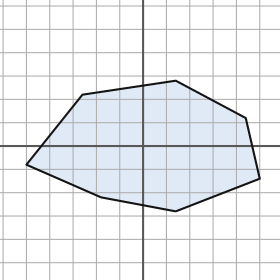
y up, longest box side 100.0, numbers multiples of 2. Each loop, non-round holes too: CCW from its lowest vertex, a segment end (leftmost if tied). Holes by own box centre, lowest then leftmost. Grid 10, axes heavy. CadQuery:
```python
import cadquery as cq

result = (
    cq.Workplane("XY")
    .moveTo(14.0, -28.0)
    .lineTo(50.0, -14.0)
    .lineTo(44.0, 12.0)
    .lineTo(14.0, 28.0)
    .lineTo(-26.0, 22.0)
    .lineTo(-50.0, -8.0)
    .lineTo(-18.0, -22.0)
    .close()
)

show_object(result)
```